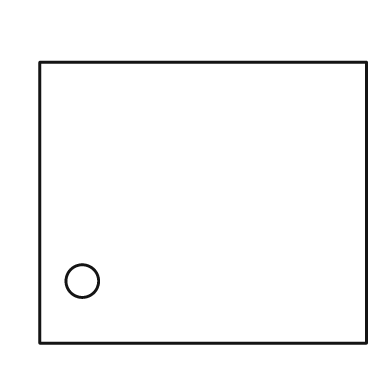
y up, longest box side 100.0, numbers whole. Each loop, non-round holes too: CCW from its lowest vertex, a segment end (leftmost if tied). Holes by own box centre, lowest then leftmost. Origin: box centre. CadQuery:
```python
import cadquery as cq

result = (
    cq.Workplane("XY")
    .moveTo(-50.0, -43.0)
    .lineTo(50.0, -43.0)
    .lineTo(50.0, 43.0)
    .lineTo(-50.0, 43.0)
    .close()
    .moveTo(-37.0, -24.0)
    .circle(5.0)
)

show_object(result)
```